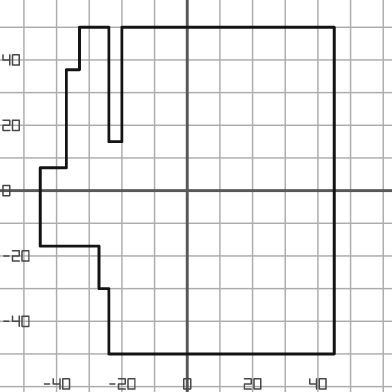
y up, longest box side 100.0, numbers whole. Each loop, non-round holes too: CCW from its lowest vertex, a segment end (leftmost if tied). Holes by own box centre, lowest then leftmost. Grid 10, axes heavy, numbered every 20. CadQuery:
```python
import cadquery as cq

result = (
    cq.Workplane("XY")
    .moveTo(-24.0, -50.0)
    .lineTo(45.0, -50.0)
    .lineTo(45.0, 50.0)
    .lineTo(-20.0, 50.0)
    .lineTo(-20.0, 15.0)
    .lineTo(-24.0, 15.0)
    .lineTo(-24.0, 50.0)
    .lineTo(-33.0, 50.0)
    .lineTo(-33.0, 37.0)
    .lineTo(-37.0, 37.0)
    .lineTo(-37.0, 7.0)
    .lineTo(-45.0, 7.0)
    .lineTo(-45.0, -17.0)
    .lineTo(-27.0, -17.0)
    .lineTo(-27.0, -30.0)
    .lineTo(-24.0, -30.0)
    .close()
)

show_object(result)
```